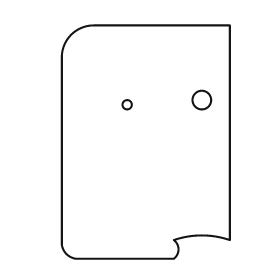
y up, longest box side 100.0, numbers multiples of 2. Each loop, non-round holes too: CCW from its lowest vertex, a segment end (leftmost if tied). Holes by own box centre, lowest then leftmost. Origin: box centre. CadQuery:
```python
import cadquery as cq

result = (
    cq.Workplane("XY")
    .moveTo(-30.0, -50.0)
    .lineTo(12.0, -50.0)
    .threePointArc((14.0, -46.0), (12.0, -42.0))
    .threePointArc((24.0, -40.0), (36.0, -42.0))
    .lineTo(36.0, 50.0)
    .lineTo(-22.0, 50.0)
    .threePointArc((-32.0, 46.0), (-36.0, 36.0))
    .lineTo(-36.0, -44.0)
    .threePointArc((-34.0, -48.0), (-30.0, -50.0))
    .close()
    .moveTo(-8.0, 16.0)
    .circle(2.0)
    .moveTo(24.0, 18.0)
    .circle(4.0)
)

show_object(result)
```